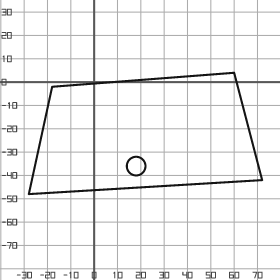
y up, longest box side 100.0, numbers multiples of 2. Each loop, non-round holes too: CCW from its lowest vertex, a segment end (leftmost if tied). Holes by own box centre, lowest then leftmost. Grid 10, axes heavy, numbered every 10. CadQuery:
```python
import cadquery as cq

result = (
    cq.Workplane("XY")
    .moveTo(-28.0, -48.0)
    .lineTo(72.0, -42.0)
    .lineTo(60.0, 4.0)
    .lineTo(-18.0, -2.0)
    .close()
    .moveTo(18.0, -36.0)
    .circle(4.0)
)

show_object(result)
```